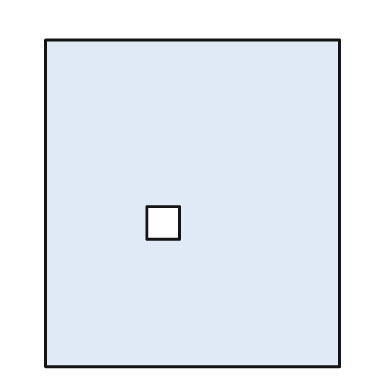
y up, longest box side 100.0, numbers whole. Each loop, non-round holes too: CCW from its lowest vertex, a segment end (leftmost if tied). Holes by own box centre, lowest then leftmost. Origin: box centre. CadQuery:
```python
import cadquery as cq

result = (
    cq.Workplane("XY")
    .moveTo(-45.0, -50.0)
    .lineTo(45.0, -50.0)
    .lineTo(45.0, 50.0)
    .lineTo(-45.0, 50.0)
    .close()
    .moveTo(-14.0, -11.0)
    .lineTo(-4.0, -11.0)
    .lineTo(-4.0, -1.0)
    .lineTo(-14.0, -1.0)
    .close()
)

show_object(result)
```